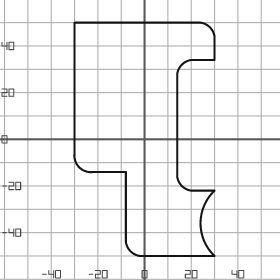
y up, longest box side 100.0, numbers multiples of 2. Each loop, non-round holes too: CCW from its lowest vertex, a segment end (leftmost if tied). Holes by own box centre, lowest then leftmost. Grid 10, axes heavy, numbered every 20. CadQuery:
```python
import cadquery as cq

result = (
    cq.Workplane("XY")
    .moveTo(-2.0, -50.0)
    .lineTo(30.0, -50.0)
    .threePointArc((24.0, -36.0), (30.0, -22.0))
    .lineTo(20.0, -22.0)
    .threePointArc((16.0, -20.0), (14.0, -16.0))
    .lineTo(14.0, 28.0)
    .threePointArc((16.0, 32.0), (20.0, 34.0))
    .lineTo(30.0, 34.0)
    .lineTo(30.0, 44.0)
    .threePointArc((28.0, 48.0), (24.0, 50.0))
    .lineTo(-30.0, 50.0)
    .lineTo(-30.0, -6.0)
    .threePointArc((-28.0, -12.0), (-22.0, -14.0))
    .lineTo(-8.0, -14.0)
    .lineTo(-8.0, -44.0)
    .threePointArc((-6.0, -48.0), (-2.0, -50.0))
    .close()
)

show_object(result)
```